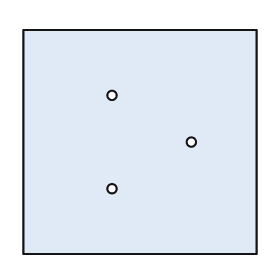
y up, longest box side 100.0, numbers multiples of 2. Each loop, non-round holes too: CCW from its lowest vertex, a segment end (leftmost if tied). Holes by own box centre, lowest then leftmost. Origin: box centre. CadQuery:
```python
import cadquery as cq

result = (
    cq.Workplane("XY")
    .moveTo(-50.0, -48.0)
    .lineTo(50.0, -48.0)
    .lineTo(50.0, 48.0)
    .lineTo(-50.0, 48.0)
    .close()
    .moveTo(-12.0, -20.0)
    .circle(2.0)
    .moveTo(22.0, 0.0)
    .circle(2.0)
    .moveTo(-12.0, 20.0)
    .circle(2.0)
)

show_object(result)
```